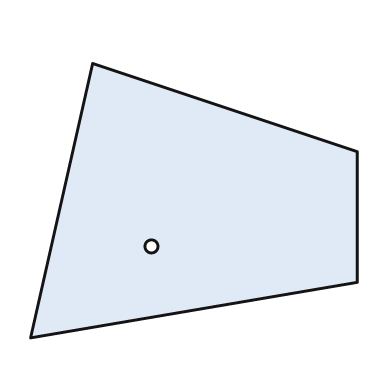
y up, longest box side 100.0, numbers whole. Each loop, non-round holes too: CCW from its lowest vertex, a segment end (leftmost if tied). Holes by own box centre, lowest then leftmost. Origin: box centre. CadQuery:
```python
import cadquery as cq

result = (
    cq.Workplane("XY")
    .moveTo(-50.0, -42.0)
    .lineTo(50.0, -25.0)
    .lineTo(50.0, 15.0)
    .lineTo(-31.0, 42.0)
    .close()
    .moveTo(-13.0, -14.0)
    .circle(2.0)
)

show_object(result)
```